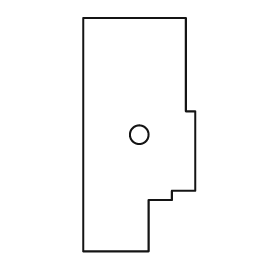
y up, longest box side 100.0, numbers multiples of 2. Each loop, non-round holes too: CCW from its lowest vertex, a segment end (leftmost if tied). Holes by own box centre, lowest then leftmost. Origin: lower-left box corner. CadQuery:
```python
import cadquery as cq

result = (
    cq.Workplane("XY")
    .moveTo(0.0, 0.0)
    .lineTo(28.0, 0.0)
    .lineTo(28.0, 22.0)
    .lineTo(38.0, 22.0)
    .lineTo(38.0, 26.0)
    .lineTo(48.0, 26.0)
    .lineTo(48.0, 60.0)
    .lineTo(44.0, 60.0)
    .lineTo(44.0, 100.0)
    .lineTo(0.0, 100.0)
    .close()
    .moveTo(24.0, 50.0)
    .circle(4.0)
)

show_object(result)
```